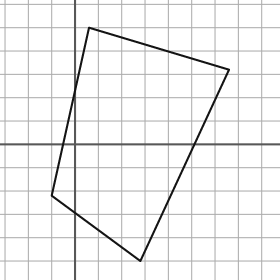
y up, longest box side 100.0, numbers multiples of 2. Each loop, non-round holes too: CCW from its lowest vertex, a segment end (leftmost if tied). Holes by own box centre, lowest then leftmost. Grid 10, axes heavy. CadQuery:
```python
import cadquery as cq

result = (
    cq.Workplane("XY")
    .moveTo(28.0, -50.0)
    .lineTo(66.0, 32.0)
    .lineTo(6.0, 50.0)
    .lineTo(-10.0, -22.0)
    .close()
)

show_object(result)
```